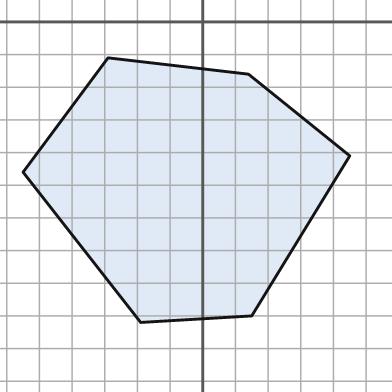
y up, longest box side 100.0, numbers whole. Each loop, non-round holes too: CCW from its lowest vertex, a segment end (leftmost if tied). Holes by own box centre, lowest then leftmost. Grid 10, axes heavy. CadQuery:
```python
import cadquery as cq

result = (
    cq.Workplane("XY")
    .moveTo(-19.0, -92.0)
    .lineTo(15.0, -90.0)
    .lineTo(45.0, -41.0)
    .lineTo(14.0, -16.0)
    .lineTo(-29.0, -11.0)
    .lineTo(-55.0, -46.0)
    .close()
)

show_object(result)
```